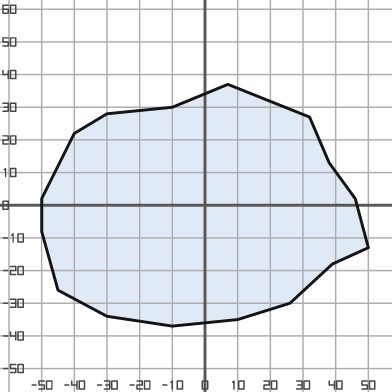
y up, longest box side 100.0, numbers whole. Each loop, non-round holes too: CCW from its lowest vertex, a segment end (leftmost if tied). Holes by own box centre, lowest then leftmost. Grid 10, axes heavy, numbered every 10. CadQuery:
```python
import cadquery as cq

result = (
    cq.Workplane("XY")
    .moveTo(-10.0, -37.0)
    .lineTo(10.0, -35.0)
    .lineTo(26.0, -30.0)
    .lineTo(39.0, -18.0)
    .lineTo(50.0, -13.0)
    .lineTo(46.0, 2.0)
    .lineTo(38.0, 13.0)
    .lineTo(32.0, 27.0)
    .lineTo(7.0, 37.0)
    .lineTo(-10.0, 30.0)
    .lineTo(-30.0, 28.0)
    .lineTo(-40.0, 22.0)
    .lineTo(-50.0, 2.0)
    .lineTo(-50.0, -8.0)
    .lineTo(-45.0, -26.0)
    .lineTo(-30.0, -34.0)
    .close()
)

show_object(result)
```